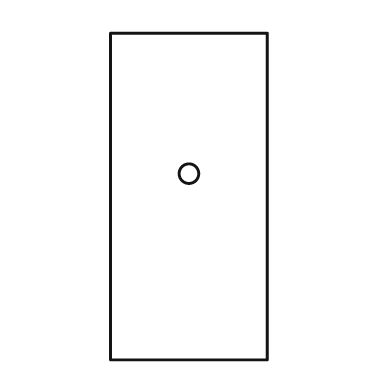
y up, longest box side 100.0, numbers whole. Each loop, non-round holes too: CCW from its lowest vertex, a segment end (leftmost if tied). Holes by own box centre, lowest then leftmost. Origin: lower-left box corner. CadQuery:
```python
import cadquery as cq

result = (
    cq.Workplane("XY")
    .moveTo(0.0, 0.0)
    .lineTo(48.0, 0.0)
    .lineTo(48.0, 100.0)
    .lineTo(0.0, 100.0)
    .close()
    .moveTo(24.0, 57.0)
    .circle(3.0)
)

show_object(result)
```